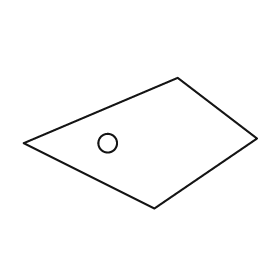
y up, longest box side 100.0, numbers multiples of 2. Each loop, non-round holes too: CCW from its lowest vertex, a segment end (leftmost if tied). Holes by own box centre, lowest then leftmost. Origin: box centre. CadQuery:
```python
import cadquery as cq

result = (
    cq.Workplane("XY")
    .moveTo(6.0, -28.0)
    .lineTo(50.0, 2.0)
    .lineTo(16.0, 28.0)
    .lineTo(-50.0, 0.0)
    .close()
    .moveTo(-14.0, 0.0)
    .circle(4.0)
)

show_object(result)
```